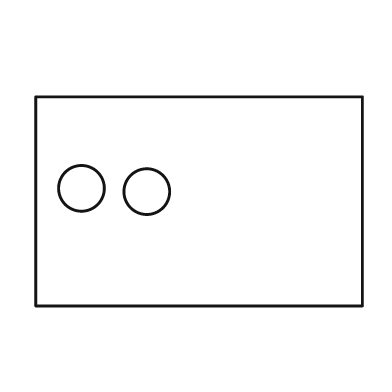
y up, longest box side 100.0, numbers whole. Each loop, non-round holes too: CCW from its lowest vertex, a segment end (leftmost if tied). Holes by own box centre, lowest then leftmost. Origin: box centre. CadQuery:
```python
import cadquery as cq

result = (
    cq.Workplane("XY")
    .moveTo(-50.0, -32.0)
    .lineTo(50.0, -32.0)
    .lineTo(50.0, 32.0)
    .lineTo(-50.0, 32.0)
    .close()
    .moveTo(-16.0, 3.0)
    .circle(7.0)
    .moveTo(-36.0, 4.0)
    .circle(7.0)
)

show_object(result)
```